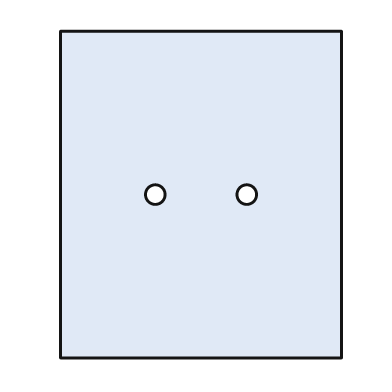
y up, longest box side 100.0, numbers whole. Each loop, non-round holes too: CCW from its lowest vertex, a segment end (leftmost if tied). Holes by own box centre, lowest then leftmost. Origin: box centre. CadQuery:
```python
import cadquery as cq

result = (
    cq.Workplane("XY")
    .moveTo(-43.0, -50.0)
    .lineTo(43.0, -50.0)
    .lineTo(43.0, 50.0)
    .lineTo(-43.0, 50.0)
    .close()
    .moveTo(-14.0, 0.0)
    .circle(3.0)
    .moveTo(14.0, 0.0)
    .circle(3.0)
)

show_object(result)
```